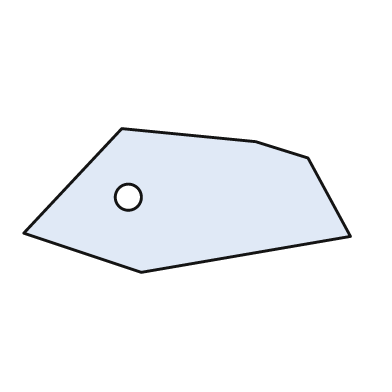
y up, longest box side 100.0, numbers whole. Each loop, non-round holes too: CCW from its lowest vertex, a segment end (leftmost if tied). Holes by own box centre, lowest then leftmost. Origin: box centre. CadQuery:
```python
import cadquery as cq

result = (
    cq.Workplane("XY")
    .moveTo(-14.0, -22.0)
    .lineTo(50.0, -11.0)
    .lineTo(37.0, 13.0)
    .lineTo(21.0, 18.0)
    .lineTo(-20.0, 22.0)
    .lineTo(-50.0, -10.0)
    .close()
    .moveTo(-18.0, 1.0)
    .circle(4.0)
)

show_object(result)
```